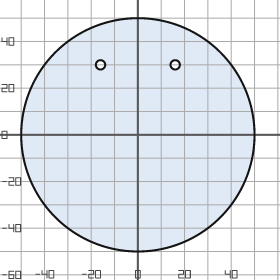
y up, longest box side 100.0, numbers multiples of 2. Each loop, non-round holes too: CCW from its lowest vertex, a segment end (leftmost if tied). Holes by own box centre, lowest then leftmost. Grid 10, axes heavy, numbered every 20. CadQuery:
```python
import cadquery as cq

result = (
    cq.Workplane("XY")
    .moveTo(0.0, 0.0)
    .circle(50.0)
    .moveTo(-16.0, 30.0)
    .circle(2.0)
    .moveTo(16.0, 30.0)
    .circle(2.0)
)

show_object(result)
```